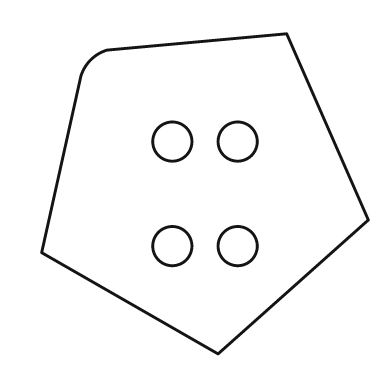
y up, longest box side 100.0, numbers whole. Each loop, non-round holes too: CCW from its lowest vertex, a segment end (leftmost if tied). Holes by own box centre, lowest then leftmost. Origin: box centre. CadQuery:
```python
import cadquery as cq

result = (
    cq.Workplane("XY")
    .moveTo(4.0, -49.0)
    .lineTo(50.0, -8.0)
    .lineTo(25.0, 49.0)
    .lineTo(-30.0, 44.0)
    .threePointArc((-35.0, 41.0), (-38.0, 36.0))
    .lineTo(-50.0, -18.0)
    .close()
    .moveTo(-10.0, -16.0)
    .circle(6.0)
    .moveTo(10.0, -16.0)
    .circle(6.0)
    .moveTo(-10.0, 16.0)
    .circle(6.0)
    .moveTo(10.0, 16.0)
    .circle(6.0)
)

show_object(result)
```